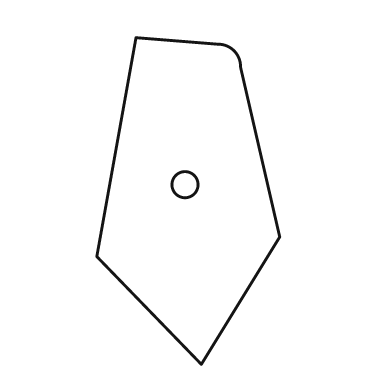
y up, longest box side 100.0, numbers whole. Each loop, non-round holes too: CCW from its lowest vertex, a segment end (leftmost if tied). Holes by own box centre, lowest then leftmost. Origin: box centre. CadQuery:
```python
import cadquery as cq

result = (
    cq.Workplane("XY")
    .moveTo(4.0, -50.0)
    .lineTo(28.0, -11.0)
    .lineTo(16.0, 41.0)
    .threePointArc((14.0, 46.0), (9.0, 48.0))
    .lineTo(-16.0, 50.0)
    .lineTo(-28.0, -17.0)
    .close()
    .moveTo(-1.0, 5.0)
    .circle(4.0)
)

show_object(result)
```